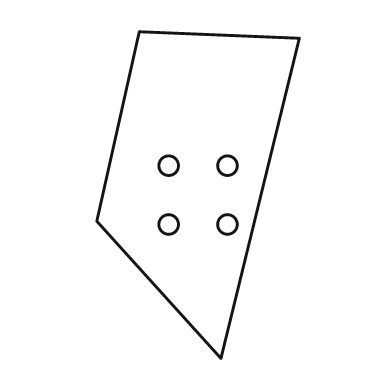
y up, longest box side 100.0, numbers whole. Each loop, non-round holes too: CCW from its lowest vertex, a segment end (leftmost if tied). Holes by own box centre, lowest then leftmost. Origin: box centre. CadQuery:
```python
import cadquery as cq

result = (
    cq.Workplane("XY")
    .moveTo(7.0, -50.0)
    .lineTo(31.0, 48.0)
    .lineTo(-18.0, 50.0)
    .lineTo(-31.0, -8.0)
    .close()
    .moveTo(-9.0, -9.0)
    .circle(3.0)
    .moveTo(9.0, -9.0)
    .circle(3.0)
    .moveTo(-9.0, 9.0)
    .circle(3.0)
    .moveTo(9.0, 9.0)
    .circle(3.0)
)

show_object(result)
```